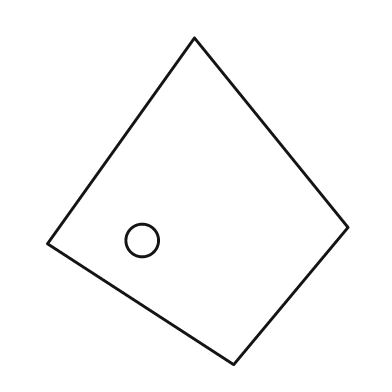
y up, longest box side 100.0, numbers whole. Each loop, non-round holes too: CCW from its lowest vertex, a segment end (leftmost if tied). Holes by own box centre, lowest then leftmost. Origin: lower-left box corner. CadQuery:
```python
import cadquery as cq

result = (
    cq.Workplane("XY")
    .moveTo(57.0, 0.0)
    .lineTo(92.0, 42.0)
    .lineTo(45.0, 100.0)
    .lineTo(0.0, 37.0)
    .close()
    .moveTo(29.0, 38.0)
    .circle(5.0)
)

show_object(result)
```